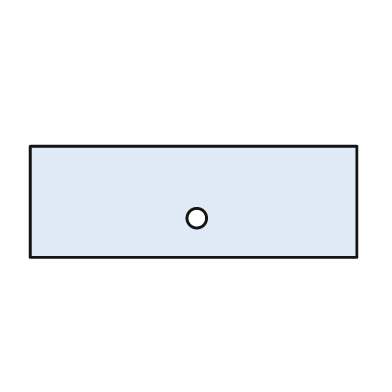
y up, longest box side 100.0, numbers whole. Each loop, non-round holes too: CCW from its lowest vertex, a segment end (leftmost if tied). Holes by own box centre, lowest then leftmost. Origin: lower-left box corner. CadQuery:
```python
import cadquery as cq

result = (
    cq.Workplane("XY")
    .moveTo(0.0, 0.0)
    .lineTo(100.0, 0.0)
    .lineTo(100.0, 34.0)
    .lineTo(0.0, 34.0)
    .close()
    .moveTo(51.0, 12.0)
    .circle(3.0)
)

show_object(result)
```